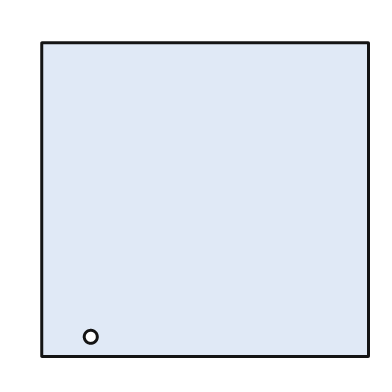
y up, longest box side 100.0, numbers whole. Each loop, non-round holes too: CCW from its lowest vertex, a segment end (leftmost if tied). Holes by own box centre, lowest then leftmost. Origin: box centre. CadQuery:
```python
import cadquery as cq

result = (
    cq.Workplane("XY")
    .moveTo(-50.0, -48.0)
    .lineTo(50.0, -48.0)
    .lineTo(50.0, 48.0)
    .lineTo(-50.0, 48.0)
    .close()
    .moveTo(-35.0, -42.0)
    .circle(2.0)
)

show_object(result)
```